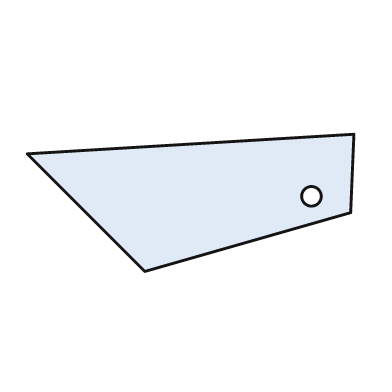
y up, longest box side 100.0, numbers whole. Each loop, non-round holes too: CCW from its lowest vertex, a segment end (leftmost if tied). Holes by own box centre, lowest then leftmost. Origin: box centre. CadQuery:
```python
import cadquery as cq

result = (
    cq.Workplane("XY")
    .moveTo(-14.0, -21.0)
    .lineTo(49.0, -3.0)
    .lineTo(50.0, 21.0)
    .lineTo(-50.0, 15.0)
    .close()
    .moveTo(37.0, 2.0)
    .circle(3.0)
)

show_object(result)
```